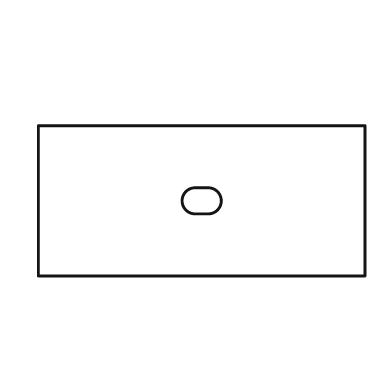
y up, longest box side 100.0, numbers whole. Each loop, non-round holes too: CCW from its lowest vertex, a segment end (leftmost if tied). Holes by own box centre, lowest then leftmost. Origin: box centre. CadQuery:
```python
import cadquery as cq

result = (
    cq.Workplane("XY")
    .moveTo(-50.0, -23.0)
    .lineTo(50.0, -23.0)
    .lineTo(50.0, 23.0)
    .lineTo(-50.0, 23.0)
    .close()
    .moveTo(-2.0, -4.0)
    .lineTo(2.0, -4.0)
    .threePointArc((6.0, 0.0), (2.0, 4.0))
    .lineTo(-2.0, 4.0)
    .threePointArc((-6.0, 0.0), (-2.0, -4.0))
    .close()
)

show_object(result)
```